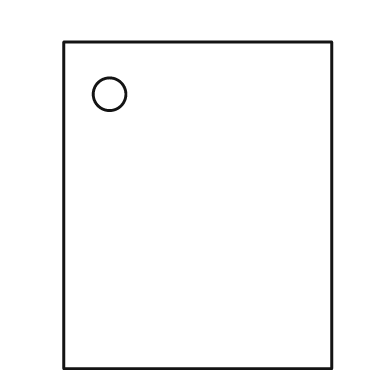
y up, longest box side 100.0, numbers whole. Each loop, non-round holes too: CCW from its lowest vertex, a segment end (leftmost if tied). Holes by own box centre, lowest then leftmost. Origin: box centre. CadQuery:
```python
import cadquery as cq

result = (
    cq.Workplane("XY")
    .moveTo(-41.0, -50.0)
    .lineTo(41.0, -50.0)
    .lineTo(41.0, 50.0)
    .lineTo(-41.0, 50.0)
    .close()
    .moveTo(-27.0, 34.0)
    .circle(5.0)
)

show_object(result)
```